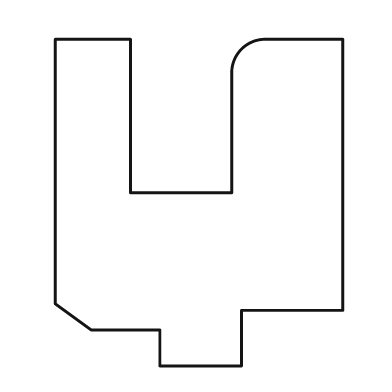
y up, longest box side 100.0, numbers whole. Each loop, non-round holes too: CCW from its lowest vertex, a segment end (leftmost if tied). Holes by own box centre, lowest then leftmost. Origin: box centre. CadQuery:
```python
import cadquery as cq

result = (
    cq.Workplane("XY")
    .moveTo(-12.0, -50.0)
    .lineTo(13.0, -50.0)
    .lineTo(13.0, -33.0)
    .lineTo(44.0, -33.0)
    .lineTo(44.0, 50.0)
    .lineTo(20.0, 50.0)
    .threePointArc((13.0, 47.0), (10.0, 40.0))
    .lineTo(10.0, 3.0)
    .lineTo(-21.0, 3.0)
    .lineTo(-21.0, 50.0)
    .lineTo(-44.0, 50.0)
    .lineTo(-44.0, -31.0)
    .lineTo(-33.0, -39.0)
    .lineTo(-12.0, -39.0)
    .close()
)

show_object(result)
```